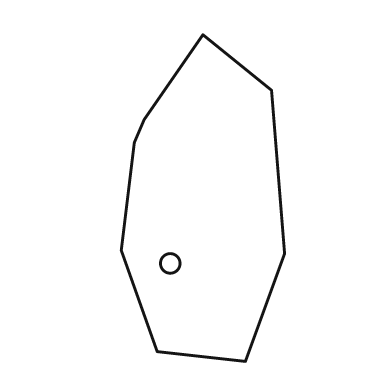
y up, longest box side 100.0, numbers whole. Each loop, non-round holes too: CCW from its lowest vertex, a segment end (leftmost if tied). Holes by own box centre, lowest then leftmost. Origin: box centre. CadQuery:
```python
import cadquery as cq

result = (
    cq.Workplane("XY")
    .moveTo(13.0, -50.0)
    .lineTo(25.0, -17.0)
    .lineTo(21.0, 33.0)
    .lineTo(0.0, 50.0)
    .lineTo(-18.0, 24.0)
    .lineTo(-21.0, 17.0)
    .lineTo(-25.0, -16.0)
    .lineTo(-14.0, -47.0)
    .close()
    .moveTo(-10.0, -20.0)
    .circle(3.0)
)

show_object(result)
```